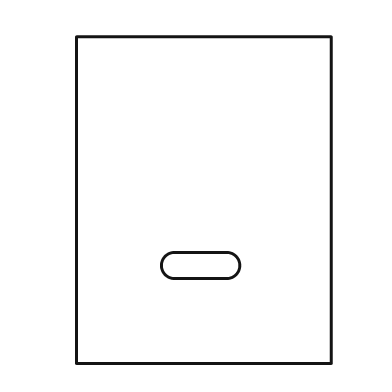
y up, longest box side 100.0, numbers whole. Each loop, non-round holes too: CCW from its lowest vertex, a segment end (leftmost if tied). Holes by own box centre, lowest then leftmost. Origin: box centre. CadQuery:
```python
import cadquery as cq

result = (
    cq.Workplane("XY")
    .moveTo(-39.0, -50.0)
    .lineTo(39.0, -50.0)
    .lineTo(39.0, 50.0)
    .lineTo(-39.0, 50.0)
    .close()
    .moveTo(-9.0, -24.0)
    .lineTo(7.0, -24.0)
    .threePointArc((11.0, -20.0), (7.0, -16.0))
    .lineTo(-9.0, -16.0)
    .threePointArc((-13.0, -20.0), (-9.0, -24.0))
    .close()
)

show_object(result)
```